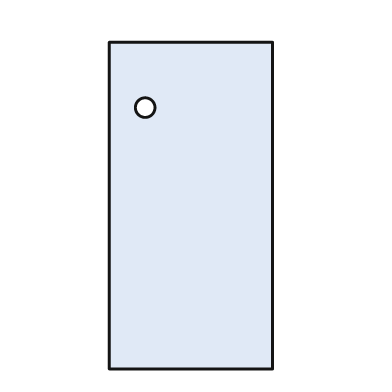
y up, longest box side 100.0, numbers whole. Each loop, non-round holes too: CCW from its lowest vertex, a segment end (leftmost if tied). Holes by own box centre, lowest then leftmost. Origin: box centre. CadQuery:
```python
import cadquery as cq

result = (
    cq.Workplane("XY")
    .moveTo(-25.0, -50.0)
    .lineTo(25.0, -50.0)
    .lineTo(25.0, 50.0)
    .lineTo(-25.0, 50.0)
    .close()
    .moveTo(-14.0, 30.0)
    .circle(3.0)
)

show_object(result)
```